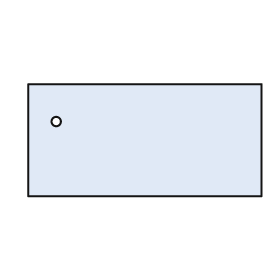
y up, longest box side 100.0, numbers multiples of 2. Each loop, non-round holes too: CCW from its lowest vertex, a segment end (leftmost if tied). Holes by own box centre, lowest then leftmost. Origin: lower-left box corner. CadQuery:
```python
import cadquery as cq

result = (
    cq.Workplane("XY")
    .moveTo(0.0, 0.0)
    .lineTo(100.0, 0.0)
    .lineTo(100.0, 48.0)
    .lineTo(0.0, 48.0)
    .close()
    .moveTo(12.0, 32.0)
    .circle(2.0)
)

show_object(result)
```